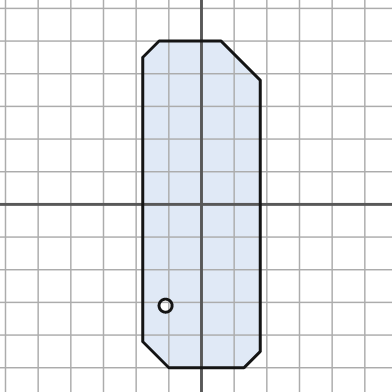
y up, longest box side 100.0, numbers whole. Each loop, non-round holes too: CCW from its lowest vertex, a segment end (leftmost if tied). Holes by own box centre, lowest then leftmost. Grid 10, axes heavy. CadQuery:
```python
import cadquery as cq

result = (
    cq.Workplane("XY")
    .moveTo(-10.0, -50.0)
    .lineTo(13.0, -50.0)
    .lineTo(18.0, -45.0)
    .lineTo(18.0, 38.0)
    .lineTo(6.0, 50.0)
    .lineTo(-13.0, 50.0)
    .lineTo(-18.0, 45.0)
    .lineTo(-18.0, -42.0)
    .close()
    .moveTo(-11.0, -31.0)
    .circle(2.0)
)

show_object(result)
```